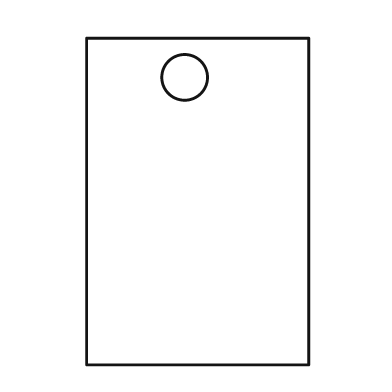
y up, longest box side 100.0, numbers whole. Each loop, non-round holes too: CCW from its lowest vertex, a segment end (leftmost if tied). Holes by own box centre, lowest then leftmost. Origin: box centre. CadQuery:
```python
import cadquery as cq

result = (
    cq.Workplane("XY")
    .moveTo(-34.0, -50.0)
    .lineTo(34.0, -50.0)
    .lineTo(34.0, 50.0)
    .lineTo(-34.0, 50.0)
    .close()
    .moveTo(-4.0, 38.0)
    .circle(7.0)
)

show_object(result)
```